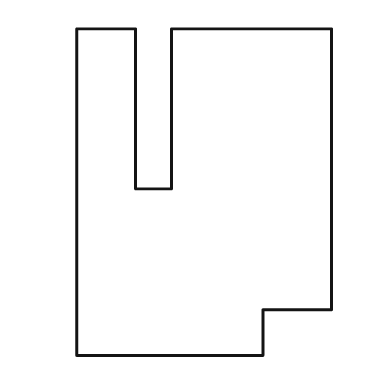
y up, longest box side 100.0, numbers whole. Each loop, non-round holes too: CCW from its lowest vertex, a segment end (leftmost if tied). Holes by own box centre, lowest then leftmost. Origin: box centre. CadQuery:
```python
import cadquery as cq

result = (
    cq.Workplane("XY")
    .moveTo(-39.0, -50.0)
    .lineTo(18.0, -50.0)
    .lineTo(18.0, -36.0)
    .lineTo(39.0, -36.0)
    .lineTo(39.0, 50.0)
    .lineTo(-10.0, 50.0)
    .lineTo(-10.0, 1.0)
    .lineTo(-21.0, 1.0)
    .lineTo(-21.0, 50.0)
    .lineTo(-39.0, 50.0)
    .close()
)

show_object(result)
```